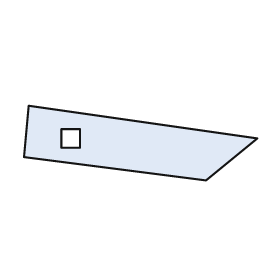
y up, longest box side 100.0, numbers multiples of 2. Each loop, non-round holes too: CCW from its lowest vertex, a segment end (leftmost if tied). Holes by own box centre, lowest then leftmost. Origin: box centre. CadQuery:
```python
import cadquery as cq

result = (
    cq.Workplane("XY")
    .moveTo(28.0, -16.0)
    .lineTo(50.0, 2.0)
    .lineTo(-48.0, 16.0)
    .lineTo(-50.0, -6.0)
    .close()
    .moveTo(-34.0, -2.0)
    .lineTo(-26.0, -2.0)
    .lineTo(-26.0, 6.0)
    .lineTo(-34.0, 6.0)
    .close()
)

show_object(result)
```